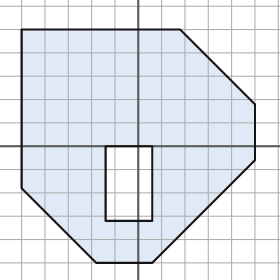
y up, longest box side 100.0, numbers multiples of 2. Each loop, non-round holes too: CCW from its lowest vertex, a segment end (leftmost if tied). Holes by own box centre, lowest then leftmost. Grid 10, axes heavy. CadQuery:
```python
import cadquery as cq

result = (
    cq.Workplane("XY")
    .moveTo(-18.0, -50.0)
    .lineTo(6.0, -50.0)
    .lineTo(50.0, -6.0)
    .lineTo(50.0, 18.0)
    .lineTo(18.0, 50.0)
    .lineTo(-50.0, 50.0)
    .lineTo(-50.0, -18.0)
    .close()
    .moveTo(-14.0, -32.0)
    .lineTo(6.0, -32.0)
    .lineTo(6.0, 0.0)
    .lineTo(-14.0, 0.0)
    .close()
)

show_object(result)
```